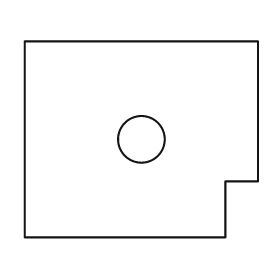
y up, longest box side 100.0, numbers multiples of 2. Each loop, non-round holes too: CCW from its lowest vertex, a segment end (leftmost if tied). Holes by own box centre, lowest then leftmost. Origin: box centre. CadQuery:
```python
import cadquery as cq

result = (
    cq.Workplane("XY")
    .moveTo(-50.0, -42.0)
    .lineTo(36.0, -42.0)
    .lineTo(36.0, -18.0)
    .lineTo(50.0, -18.0)
    .lineTo(50.0, 42.0)
    .lineTo(-50.0, 42.0)
    .close()
    .moveTo(0.0, 0.0)
    .circle(10.0)
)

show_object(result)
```